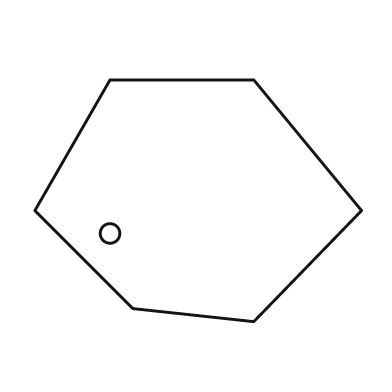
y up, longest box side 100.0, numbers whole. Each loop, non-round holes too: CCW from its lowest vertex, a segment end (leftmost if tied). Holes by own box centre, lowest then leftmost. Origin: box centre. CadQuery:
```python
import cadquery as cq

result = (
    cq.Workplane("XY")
    .moveTo(17.0, -37.0)
    .lineTo(50.0, -3.0)
    .lineTo(17.0, 37.0)
    .lineTo(-27.0, 37.0)
    .lineTo(-50.0, -3.0)
    .lineTo(-20.0, -33.0)
    .close()
    .moveTo(-27.0, -10.0)
    .circle(3.0)
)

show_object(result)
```